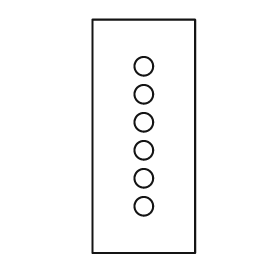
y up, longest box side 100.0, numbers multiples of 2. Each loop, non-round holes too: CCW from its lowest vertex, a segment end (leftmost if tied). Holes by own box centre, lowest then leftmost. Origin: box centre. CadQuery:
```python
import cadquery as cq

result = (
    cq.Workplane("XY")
    .moveTo(-22.0, -50.0)
    .lineTo(22.0, -50.0)
    .lineTo(22.0, 50.0)
    .lineTo(-22.0, 50.0)
    .close()
    .moveTo(0.0, -30.0)
    .circle(4.0)
    .moveTo(0.0, -18.0)
    .circle(4.0)
    .moveTo(0.0, -6.0)
    .circle(4.0)
    .moveTo(0.0, 6.0)
    .circle(4.0)
    .moveTo(0.0, 18.0)
    .circle(4.0)
    .moveTo(0.0, 30.0)
    .circle(4.0)
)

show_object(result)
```